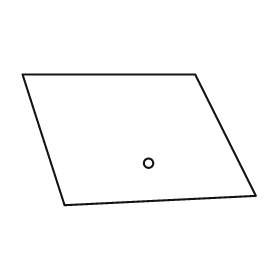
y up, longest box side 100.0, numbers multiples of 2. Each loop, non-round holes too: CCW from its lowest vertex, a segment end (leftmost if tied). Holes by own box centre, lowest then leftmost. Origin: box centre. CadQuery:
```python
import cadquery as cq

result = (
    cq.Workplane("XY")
    .moveTo(-32.0, -28.0)
    .lineTo(50.0, -24.0)
    .lineTo(24.0, 28.0)
    .lineTo(-50.0, 28.0)
    .close()
    .moveTo(4.0, -10.0)
    .circle(2.0)
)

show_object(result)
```